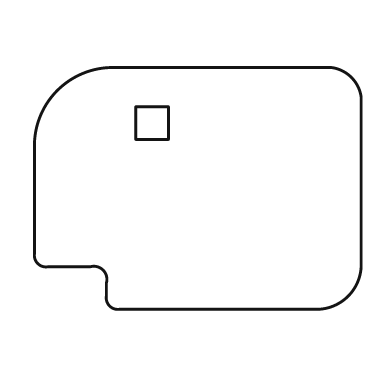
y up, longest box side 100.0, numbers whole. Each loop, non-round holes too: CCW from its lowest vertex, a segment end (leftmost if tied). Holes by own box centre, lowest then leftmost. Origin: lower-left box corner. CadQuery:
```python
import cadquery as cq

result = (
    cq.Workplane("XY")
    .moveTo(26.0, 0.0)
    .lineTo(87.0, 0.0)
    .threePointArc((96.0, 4.0), (100.0, 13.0))
    .lineTo(100.0, 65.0)
    .threePointArc((97.0, 71.0), (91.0, 74.0))
    .lineTo(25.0, 74.0)
    .threePointArc((7.0, 67.0), (0.0, 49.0))
    .lineTo(0.0, 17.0)
    .threePointArc((1.0, 14.0), (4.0, 13.0))
    .lineTo(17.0, 13.0)
    .threePointArc((21.0, 12.0), (22.0, 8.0))
    .lineTo(22.0, 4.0)
    .threePointArc((23.0, 1.0), (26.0, 0.0))
    .close()
    .moveTo(31.0, 52.0)
    .lineTo(41.0, 52.0)
    .lineTo(41.0, 62.0)
    .lineTo(31.0, 62.0)
    .close()
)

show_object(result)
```